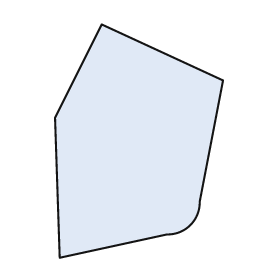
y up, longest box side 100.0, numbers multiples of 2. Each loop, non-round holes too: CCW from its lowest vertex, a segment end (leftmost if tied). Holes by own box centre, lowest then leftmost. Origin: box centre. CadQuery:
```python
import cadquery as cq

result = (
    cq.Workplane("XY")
    .moveTo(-34.0, -50.0)
    .lineTo(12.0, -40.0)
    .threePointArc((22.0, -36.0), (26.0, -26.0))
    .lineTo(36.0, 26.0)
    .lineTo(-16.0, 50.0)
    .lineTo(-36.0, 10.0)
    .close()
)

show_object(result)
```